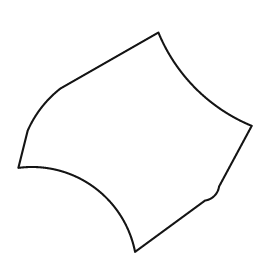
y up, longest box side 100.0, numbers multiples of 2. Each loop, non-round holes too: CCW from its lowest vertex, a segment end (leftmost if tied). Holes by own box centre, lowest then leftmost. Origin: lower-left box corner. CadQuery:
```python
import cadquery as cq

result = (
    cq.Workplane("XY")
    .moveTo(50.0, 0.0)
    .lineTo(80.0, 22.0)
    .threePointArc((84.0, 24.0), (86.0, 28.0))
    .lineTo(100.0, 54.0)
    .threePointArc((76.0, 70.0), (60.0, 94.0))
    .lineTo(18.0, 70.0)
    .threePointArc((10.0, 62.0), (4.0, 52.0))
    .lineTo(0.0, 36.0)
    .threePointArc((32.0, 28.0), (50.0, 0.0))
    .close()
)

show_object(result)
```